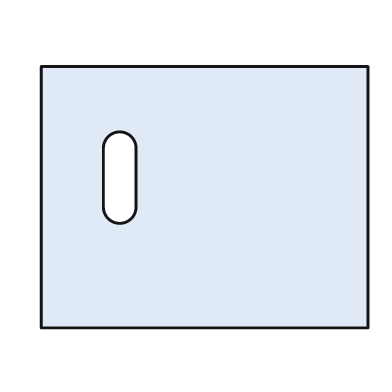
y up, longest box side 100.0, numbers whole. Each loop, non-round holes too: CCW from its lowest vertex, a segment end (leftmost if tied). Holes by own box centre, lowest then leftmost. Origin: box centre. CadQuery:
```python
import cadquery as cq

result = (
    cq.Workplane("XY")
    .moveTo(-50.0, -40.0)
    .lineTo(50.0, -40.0)
    .lineTo(50.0, 40.0)
    .lineTo(-50.0, 40.0)
    .close()
    .moveTo(-31.0, -3.0)
    .threePointArc((-26.0, -8.0), (-21.0, -3.0))
    .lineTo(-21.0, 15.0)
    .threePointArc((-26.0, 20.0), (-31.0, 15.0))
    .close()
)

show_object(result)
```